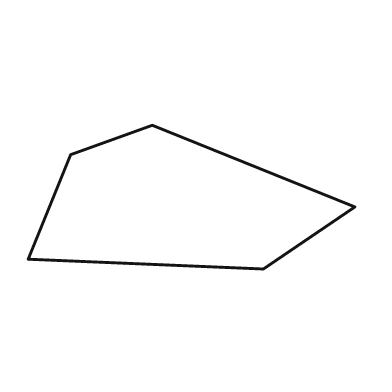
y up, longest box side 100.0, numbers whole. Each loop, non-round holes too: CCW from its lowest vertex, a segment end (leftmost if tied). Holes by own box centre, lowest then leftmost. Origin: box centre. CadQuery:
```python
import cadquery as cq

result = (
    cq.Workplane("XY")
    .moveTo(22.0, -22.0)
    .lineTo(50.0, -3.0)
    .lineTo(-12.0, 22.0)
    .lineTo(-37.0, 13.0)
    .lineTo(-50.0, -19.0)
    .close()
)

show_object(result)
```